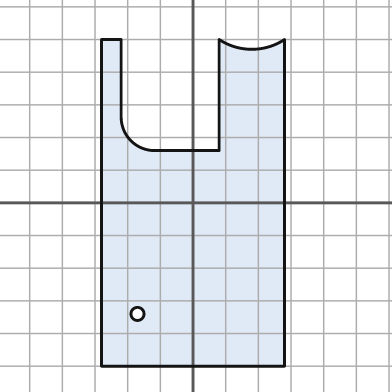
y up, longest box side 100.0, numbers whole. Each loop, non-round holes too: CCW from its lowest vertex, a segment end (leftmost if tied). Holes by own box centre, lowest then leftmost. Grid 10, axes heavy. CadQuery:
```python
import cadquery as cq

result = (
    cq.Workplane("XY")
    .moveTo(-28.0, -50.0)
    .lineTo(28.0, -50.0)
    .lineTo(28.0, 50.0)
    .threePointArc((18.0, 47.0), (8.0, 50.0))
    .lineTo(8.0, 16.0)
    .lineTo(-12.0, 16.0)
    .threePointArc((-19.0, 19.0), (-22.0, 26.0))
    .lineTo(-22.0, 50.0)
    .lineTo(-28.0, 50.0)
    .close()
    .moveTo(-17.0, -34.0)
    .circle(2.0)
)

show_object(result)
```